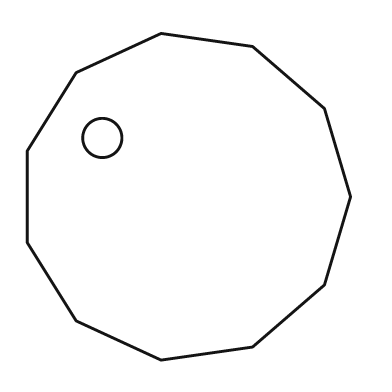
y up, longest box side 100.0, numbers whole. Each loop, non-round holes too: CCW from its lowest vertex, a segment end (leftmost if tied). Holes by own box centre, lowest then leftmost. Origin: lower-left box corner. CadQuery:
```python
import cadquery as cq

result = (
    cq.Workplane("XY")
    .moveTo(41.0, 0.0)
    .lineTo(69.0, 4.0)
    .lineTo(91.0, 23.0)
    .lineTo(99.0, 50.0)
    .lineTo(91.0, 77.0)
    .lineTo(69.0, 96.0)
    .lineTo(41.0, 100.0)
    .lineTo(15.0, 88.0)
    .lineTo(0.0, 64.0)
    .lineTo(0.0, 36.0)
    .lineTo(15.0, 12.0)
    .close()
    .moveTo(23.0, 68.0)
    .circle(6.0)
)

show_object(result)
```